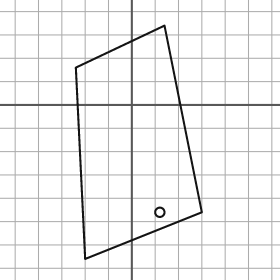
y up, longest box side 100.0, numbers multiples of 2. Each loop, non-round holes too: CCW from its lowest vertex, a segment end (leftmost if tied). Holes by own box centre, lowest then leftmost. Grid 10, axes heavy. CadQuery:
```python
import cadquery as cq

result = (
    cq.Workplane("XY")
    .moveTo(-20.0, -66.0)
    .lineTo(30.0, -46.0)
    .lineTo(14.0, 34.0)
    .lineTo(-24.0, 16.0)
    .close()
    .moveTo(12.0, -46.0)
    .circle(2.0)
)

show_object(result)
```